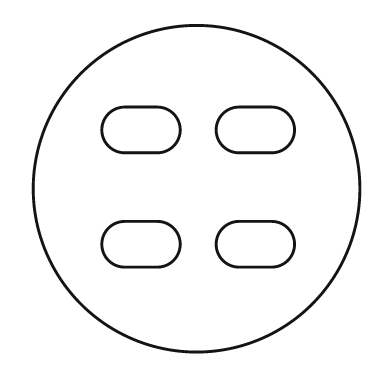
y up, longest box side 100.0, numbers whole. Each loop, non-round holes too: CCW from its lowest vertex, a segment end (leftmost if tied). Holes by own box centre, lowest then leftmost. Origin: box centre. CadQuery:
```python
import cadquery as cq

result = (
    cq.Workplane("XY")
    .moveTo(0.0, 0.0)
    .circle(50.0)
    .moveTo(-22.0, -24.0)
    .lineTo(-12.0, -24.0)
    .threePointArc((-5.0, -17.0), (-12.0, -10.0))
    .lineTo(-22.0, -10.0)
    .threePointArc((-29.0, -17.0), (-22.0, -24.0))
    .close()
    .moveTo(13.0, -24.0)
    .lineTo(23.0, -24.0)
    .threePointArc((30.0, -17.0), (23.0, -10.0))
    .lineTo(13.0, -10.0)
    .threePointArc((6.0, -17.0), (13.0, -24.0))
    .close()
    .moveTo(-22.0, 11.0)
    .lineTo(-12.0, 11.0)
    .threePointArc((-5.0, 18.0), (-12.0, 25.0))
    .lineTo(-22.0, 25.0)
    .threePointArc((-29.0, 18.0), (-22.0, 11.0))
    .close()
    .moveTo(13.0, 11.0)
    .lineTo(23.0, 11.0)
    .threePointArc((30.0, 18.0), (23.0, 25.0))
    .lineTo(13.0, 25.0)
    .threePointArc((6.0, 18.0), (13.0, 11.0))
    .close()
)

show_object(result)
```